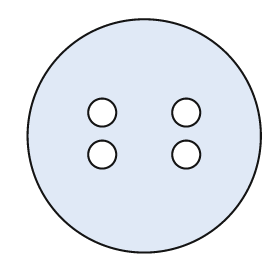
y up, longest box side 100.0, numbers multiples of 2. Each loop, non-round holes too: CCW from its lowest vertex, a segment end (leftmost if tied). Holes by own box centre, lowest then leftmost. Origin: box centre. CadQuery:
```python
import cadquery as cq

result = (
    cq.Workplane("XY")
    .moveTo(0.0, 0.0)
    .circle(50.0)
    .moveTo(-18.0, -8.0)
    .circle(6.0)
    .moveTo(18.0, -8.0)
    .circle(6.0)
    .moveTo(-18.0, 10.0)
    .circle(6.0)
    .moveTo(18.0, 10.0)
    .circle(6.0)
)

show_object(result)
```